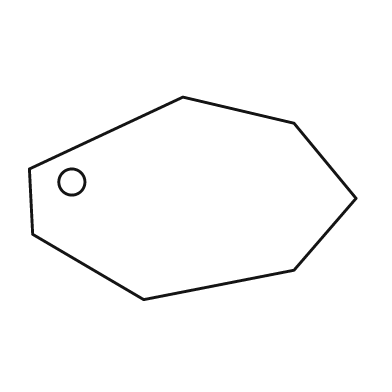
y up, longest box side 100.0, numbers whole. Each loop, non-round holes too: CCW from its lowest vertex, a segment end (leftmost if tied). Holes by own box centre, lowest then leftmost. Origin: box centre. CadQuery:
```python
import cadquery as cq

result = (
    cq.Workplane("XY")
    .moveTo(-15.0, -31.0)
    .lineTo(31.0, -22.0)
    .lineTo(50.0, 0.0)
    .lineTo(31.0, 23.0)
    .lineTo(-3.0, 31.0)
    .lineTo(-50.0, 9.0)
    .lineTo(-49.0, -11.0)
    .close()
    .moveTo(-37.0, 5.0)
    .circle(4.0)
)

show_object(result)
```